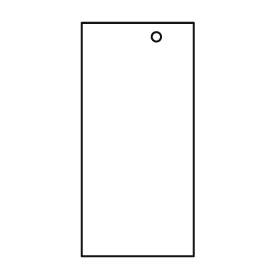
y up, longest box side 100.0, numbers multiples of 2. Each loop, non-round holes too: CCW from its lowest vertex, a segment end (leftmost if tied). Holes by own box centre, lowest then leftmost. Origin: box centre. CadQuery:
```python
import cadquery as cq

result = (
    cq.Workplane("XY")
    .moveTo(-24.0, -50.0)
    .lineTo(24.0, -50.0)
    .lineTo(24.0, 50.0)
    .lineTo(-24.0, 50.0)
    .close()
    .moveTo(8.0, 44.0)
    .circle(2.0)
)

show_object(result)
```